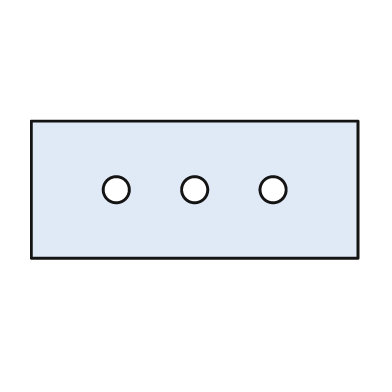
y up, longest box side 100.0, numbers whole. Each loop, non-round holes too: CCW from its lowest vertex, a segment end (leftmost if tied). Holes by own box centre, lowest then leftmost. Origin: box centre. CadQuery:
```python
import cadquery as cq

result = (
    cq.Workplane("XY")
    .moveTo(-50.0, -21.0)
    .lineTo(50.0, -21.0)
    .lineTo(50.0, 21.0)
    .lineTo(-50.0, 21.0)
    .close()
    .moveTo(-24.0, 0.0)
    .circle(4.0)
    .moveTo(0.0, 0.0)
    .circle(4.0)
    .moveTo(24.0, 0.0)
    .circle(4.0)
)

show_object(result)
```